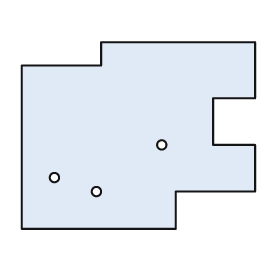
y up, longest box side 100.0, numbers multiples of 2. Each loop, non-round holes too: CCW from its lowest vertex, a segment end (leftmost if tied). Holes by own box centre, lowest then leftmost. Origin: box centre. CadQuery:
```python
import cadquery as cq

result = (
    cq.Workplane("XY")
    .moveTo(-50.0, -40.0)
    .lineTo(16.0, -40.0)
    .lineTo(16.0, -24.0)
    .lineTo(50.0, -24.0)
    .lineTo(50.0, -4.0)
    .lineTo(32.0, -4.0)
    .lineTo(32.0, 16.0)
    .lineTo(50.0, 16.0)
    .lineTo(50.0, 40.0)
    .lineTo(-16.0, 40.0)
    .lineTo(-16.0, 30.0)
    .lineTo(-50.0, 30.0)
    .close()
    .moveTo(-18.0, -24.0)
    .circle(2.0)
    .moveTo(-36.0, -18.0)
    .circle(2.0)
    .moveTo(10.0, -4.0)
    .circle(2.0)
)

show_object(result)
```